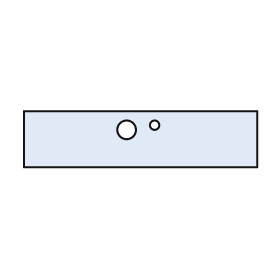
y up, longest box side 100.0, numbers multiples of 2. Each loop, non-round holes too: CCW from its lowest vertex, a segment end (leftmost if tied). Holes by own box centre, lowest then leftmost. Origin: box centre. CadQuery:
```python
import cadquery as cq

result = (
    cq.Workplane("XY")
    .moveTo(-50.0, -12.0)
    .lineTo(50.0, -12.0)
    .lineTo(50.0, 12.0)
    .lineTo(-50.0, 12.0)
    .close()
    .moveTo(-6.0, 4.0)
    .circle(4.0)
    .moveTo(6.0, 6.0)
    .circle(2.0)
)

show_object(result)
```